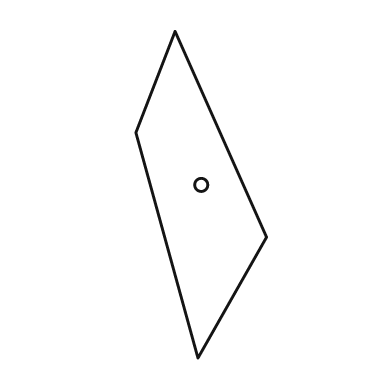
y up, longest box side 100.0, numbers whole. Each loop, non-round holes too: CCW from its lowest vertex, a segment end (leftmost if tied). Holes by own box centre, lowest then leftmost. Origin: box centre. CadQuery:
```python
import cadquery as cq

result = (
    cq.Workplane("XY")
    .moveTo(-1.0, -50.0)
    .lineTo(20.0, -13.0)
    .lineTo(-8.0, 50.0)
    .lineTo(-20.0, 19.0)
    .close()
    .moveTo(0.0, 3.0)
    .circle(2.0)
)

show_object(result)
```